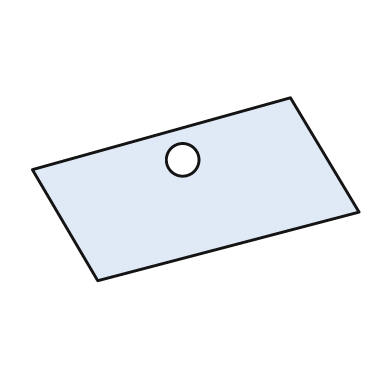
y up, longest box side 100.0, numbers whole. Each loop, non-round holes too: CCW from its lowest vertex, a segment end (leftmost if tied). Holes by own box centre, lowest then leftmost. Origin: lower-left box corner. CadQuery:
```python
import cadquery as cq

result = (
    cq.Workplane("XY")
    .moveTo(20.0, 0.0)
    .lineTo(100.0, 21.0)
    .lineTo(79.0, 56.0)
    .lineTo(0.0, 34.0)
    .close()
    .moveTo(46.0, 37.0)
    .circle(5.0)
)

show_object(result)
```